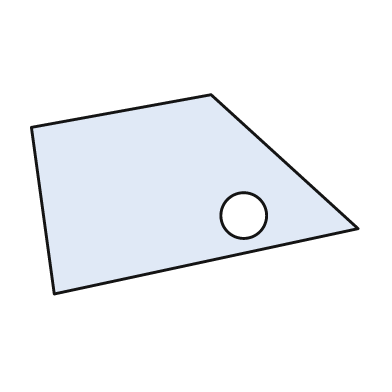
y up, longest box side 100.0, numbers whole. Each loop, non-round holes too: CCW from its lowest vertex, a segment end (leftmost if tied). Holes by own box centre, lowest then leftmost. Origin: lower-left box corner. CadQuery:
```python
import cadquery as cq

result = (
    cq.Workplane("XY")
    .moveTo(7.0, 0.0)
    .lineTo(100.0, 20.0)
    .lineTo(55.0, 61.0)
    .lineTo(0.0, 51.0)
    .close()
    .moveTo(65.0, 24.0)
    .circle(7.0)
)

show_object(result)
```